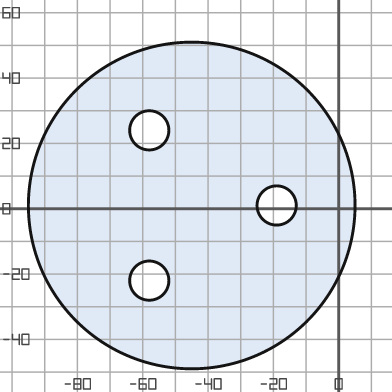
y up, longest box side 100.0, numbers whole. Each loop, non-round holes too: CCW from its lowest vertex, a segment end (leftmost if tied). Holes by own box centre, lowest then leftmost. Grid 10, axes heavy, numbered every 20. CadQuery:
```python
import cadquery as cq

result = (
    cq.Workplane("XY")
    .moveTo(-45.0, 1.0)
    .circle(50.0)
    .moveTo(-58.0, -22.0)
    .circle(6.0)
    .moveTo(-19.0, 1.0)
    .circle(6.0)
    .moveTo(-58.0, 24.0)
    .circle(6.0)
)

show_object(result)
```